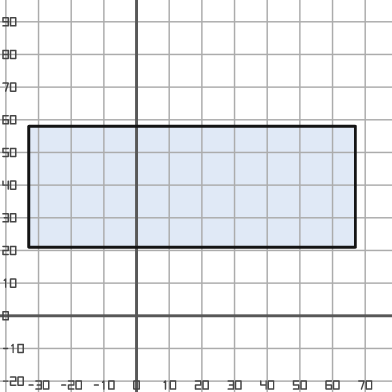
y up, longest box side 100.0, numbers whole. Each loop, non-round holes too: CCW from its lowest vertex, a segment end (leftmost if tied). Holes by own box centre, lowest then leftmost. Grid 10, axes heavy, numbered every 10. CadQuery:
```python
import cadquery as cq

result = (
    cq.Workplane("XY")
    .moveTo(-33.0, 21.0)
    .lineTo(67.0, 21.0)
    .lineTo(67.0, 58.0)
    .lineTo(-33.0, 58.0)
    .close()
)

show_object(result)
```